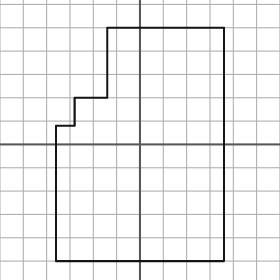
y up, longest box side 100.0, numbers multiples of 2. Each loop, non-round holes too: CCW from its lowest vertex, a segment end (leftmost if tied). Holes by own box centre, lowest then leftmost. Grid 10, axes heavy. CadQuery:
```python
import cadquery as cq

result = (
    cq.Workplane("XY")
    .moveTo(-36.0, -50.0)
    .lineTo(36.0, -50.0)
    .lineTo(36.0, 50.0)
    .lineTo(-14.0, 50.0)
    .lineTo(-14.0, 20.0)
    .lineTo(-28.0, 20.0)
    .lineTo(-28.0, 8.0)
    .lineTo(-36.0, 8.0)
    .close()
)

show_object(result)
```